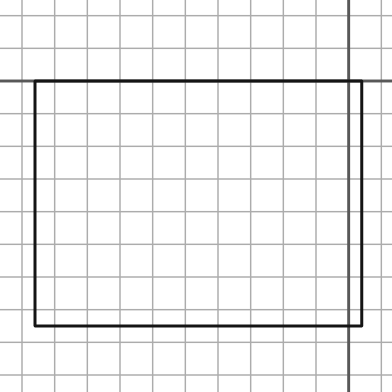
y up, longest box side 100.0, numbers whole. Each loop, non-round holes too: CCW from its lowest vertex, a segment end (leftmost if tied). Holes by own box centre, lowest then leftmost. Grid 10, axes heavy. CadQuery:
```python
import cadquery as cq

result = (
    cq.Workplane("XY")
    .moveTo(-96.0, -75.0)
    .lineTo(4.0, -75.0)
    .lineTo(4.0, 0.0)
    .lineTo(-96.0, 0.0)
    .close()
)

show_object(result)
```